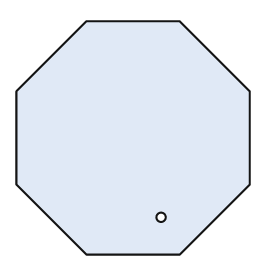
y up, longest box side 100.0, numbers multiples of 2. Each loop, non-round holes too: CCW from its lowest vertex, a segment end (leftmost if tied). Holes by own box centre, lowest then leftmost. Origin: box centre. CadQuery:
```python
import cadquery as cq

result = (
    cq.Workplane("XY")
    .moveTo(-20.0, -50.0)
    .lineTo(20.0, -50.0)
    .lineTo(50.0, -20.0)
    .lineTo(50.0, 20.0)
    .lineTo(20.0, 50.0)
    .lineTo(-20.0, 50.0)
    .lineTo(-50.0, 20.0)
    .lineTo(-50.0, -20.0)
    .close()
    .moveTo(12.0, -34.0)
    .circle(2.0)
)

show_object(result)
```